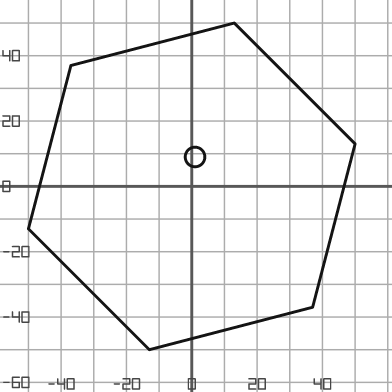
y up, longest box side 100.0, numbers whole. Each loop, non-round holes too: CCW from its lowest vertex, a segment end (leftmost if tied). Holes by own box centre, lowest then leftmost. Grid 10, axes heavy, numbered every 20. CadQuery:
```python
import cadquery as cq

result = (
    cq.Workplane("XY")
    .moveTo(-13.0, -50.0)
    .lineTo(37.0, -37.0)
    .lineTo(50.0, 13.0)
    .lineTo(13.0, 50.0)
    .lineTo(-37.0, 37.0)
    .lineTo(-50.0, -13.0)
    .close()
    .moveTo(1.0, 9.0)
    .circle(3.0)
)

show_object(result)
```